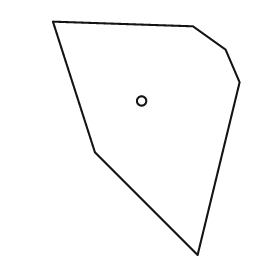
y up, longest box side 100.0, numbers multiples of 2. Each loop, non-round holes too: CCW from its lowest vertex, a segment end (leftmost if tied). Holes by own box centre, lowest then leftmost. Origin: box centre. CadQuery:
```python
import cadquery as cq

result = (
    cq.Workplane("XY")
    .moveTo(22.0, -50.0)
    .lineTo(40.0, 24.0)
    .lineTo(34.0, 38.0)
    .lineTo(20.0, 48.0)
    .lineTo(-40.0, 50.0)
    .lineTo(-22.0, -6.0)
    .close()
    .moveTo(-2.0, 16.0)
    .circle(2.0)
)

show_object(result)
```